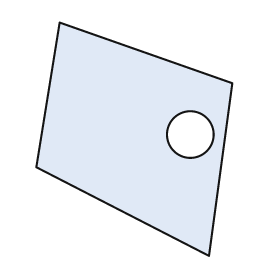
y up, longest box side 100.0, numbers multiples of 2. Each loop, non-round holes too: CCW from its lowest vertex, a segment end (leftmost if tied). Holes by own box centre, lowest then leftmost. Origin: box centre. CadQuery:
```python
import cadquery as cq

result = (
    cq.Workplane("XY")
    .moveTo(32.0, -50.0)
    .lineTo(42.0, 24.0)
    .lineTo(-32.0, 50.0)
    .lineTo(-42.0, -12.0)
    .close()
    .moveTo(24.0, 2.0)
    .circle(10.0)
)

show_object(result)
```